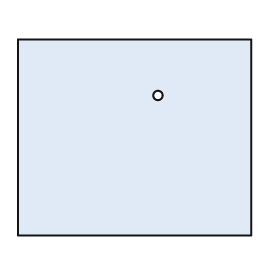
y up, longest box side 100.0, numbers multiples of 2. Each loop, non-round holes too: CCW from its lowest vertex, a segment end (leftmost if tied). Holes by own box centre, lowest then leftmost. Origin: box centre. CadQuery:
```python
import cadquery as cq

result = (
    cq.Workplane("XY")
    .moveTo(-50.0, -42.0)
    .lineTo(50.0, -42.0)
    .lineTo(50.0, 42.0)
    .lineTo(-50.0, 42.0)
    .close()
    .moveTo(10.0, 18.0)
    .circle(2.0)
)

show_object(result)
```